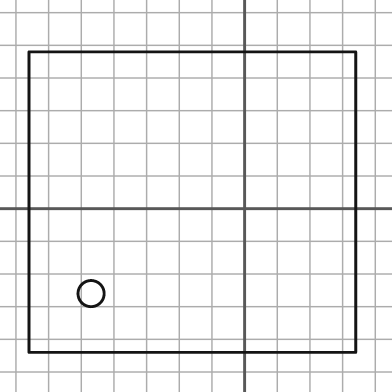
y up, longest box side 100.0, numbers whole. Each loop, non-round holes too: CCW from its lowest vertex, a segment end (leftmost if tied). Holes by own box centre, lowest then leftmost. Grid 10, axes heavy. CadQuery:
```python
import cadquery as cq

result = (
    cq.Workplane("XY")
    .moveTo(-66.0, -44.0)
    .lineTo(34.0, -44.0)
    .lineTo(34.0, 48.0)
    .lineTo(-66.0, 48.0)
    .close()
    .moveTo(-47.0, -26.0)
    .circle(4.0)
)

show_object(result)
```